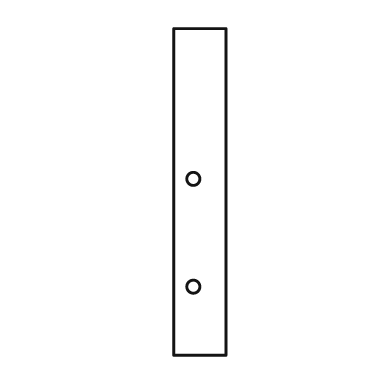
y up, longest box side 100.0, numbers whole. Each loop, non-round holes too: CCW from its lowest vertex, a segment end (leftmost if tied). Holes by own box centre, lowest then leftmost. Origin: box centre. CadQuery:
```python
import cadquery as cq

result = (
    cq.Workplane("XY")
    .moveTo(-8.0, -50.0)
    .lineTo(8.0, -50.0)
    .lineTo(8.0, 50.0)
    .lineTo(-8.0, 50.0)
    .close()
    .moveTo(-2.0, -29.0)
    .circle(2.0)
    .moveTo(-2.0, 4.0)
    .circle(2.0)
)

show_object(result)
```